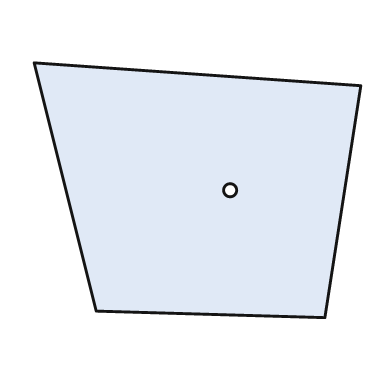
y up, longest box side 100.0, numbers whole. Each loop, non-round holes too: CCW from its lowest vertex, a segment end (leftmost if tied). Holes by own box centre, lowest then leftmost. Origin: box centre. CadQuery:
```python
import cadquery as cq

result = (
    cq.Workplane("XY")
    .moveTo(39.0, -39.0)
    .lineTo(50.0, 32.0)
    .lineTo(-50.0, 39.0)
    .lineTo(-31.0, -37.0)
    .close()
    .moveTo(10.0, 0.0)
    .circle(2.0)
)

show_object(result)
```